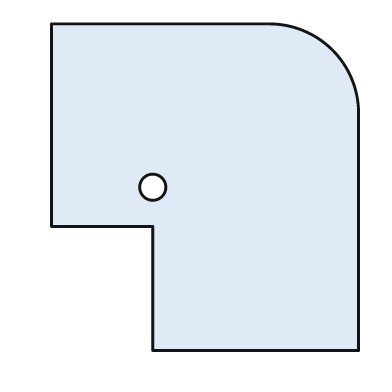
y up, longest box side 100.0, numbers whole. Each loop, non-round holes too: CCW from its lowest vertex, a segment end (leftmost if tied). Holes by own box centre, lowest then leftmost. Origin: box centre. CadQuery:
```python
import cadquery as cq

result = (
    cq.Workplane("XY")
    .moveTo(-16.0, -50.0)
    .lineTo(47.0, -50.0)
    .lineTo(47.0, 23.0)
    .threePointArc((39.0, 42.0), (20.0, 50.0))
    .lineTo(-47.0, 50.0)
    .lineTo(-47.0, -12.0)
    .lineTo(-16.0, -12.0)
    .close()
    .moveTo(-16.0, 0.0)
    .circle(4.0)
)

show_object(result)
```